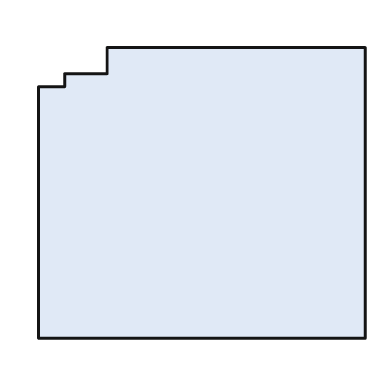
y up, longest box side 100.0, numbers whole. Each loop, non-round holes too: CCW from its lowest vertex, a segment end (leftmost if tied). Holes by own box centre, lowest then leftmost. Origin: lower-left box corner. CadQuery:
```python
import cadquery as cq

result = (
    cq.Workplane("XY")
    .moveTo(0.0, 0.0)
    .lineTo(100.0, 0.0)
    .lineTo(100.0, 89.0)
    .lineTo(21.0, 89.0)
    .lineTo(21.0, 81.0)
    .lineTo(8.0, 81.0)
    .lineTo(8.0, 77.0)
    .lineTo(0.0, 77.0)
    .close()
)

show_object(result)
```